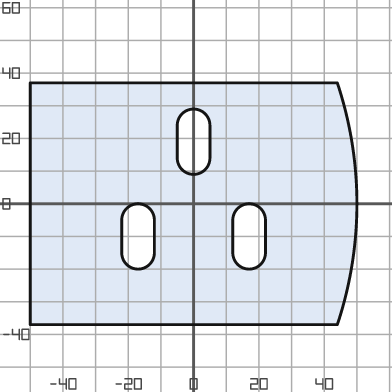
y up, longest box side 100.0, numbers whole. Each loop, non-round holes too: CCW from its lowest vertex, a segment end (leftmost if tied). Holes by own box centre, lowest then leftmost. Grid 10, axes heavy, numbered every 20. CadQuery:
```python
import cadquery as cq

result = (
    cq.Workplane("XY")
    .moveTo(-50.0, -37.0)
    .lineTo(44.0, -37.0)
    .threePointArc((50.0, 0.0), (44.0, 37.0))
    .lineTo(-50.0, 37.0)
    .close()
    .moveTo(-22.0, -15.0)
    .threePointArc((-17.0, -20.0), (-12.0, -15.0))
    .lineTo(-12.0, -5.0)
    .threePointArc((-17.0, 0.0), (-22.0, -5.0))
    .close()
    .moveTo(12.0, -15.0)
    .threePointArc((17.0, -20.0), (22.0, -15.0))
    .lineTo(22.0, -5.0)
    .threePointArc((17.0, 0.0), (12.0, -5.0))
    .close()
    .moveTo(-5.0, 14.0)
    .threePointArc((0.0, 9.0), (5.0, 14.0))
    .lineTo(5.0, 24.0)
    .threePointArc((0.0, 29.0), (-5.0, 24.0))
    .close()
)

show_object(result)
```